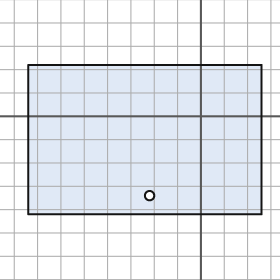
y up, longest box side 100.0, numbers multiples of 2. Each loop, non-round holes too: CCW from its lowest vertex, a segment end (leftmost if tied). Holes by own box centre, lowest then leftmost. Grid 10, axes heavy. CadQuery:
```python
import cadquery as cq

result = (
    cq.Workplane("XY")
    .moveTo(-74.0, -42.0)
    .lineTo(26.0, -42.0)
    .lineTo(26.0, 22.0)
    .lineTo(-74.0, 22.0)
    .close()
    .moveTo(-22.0, -34.0)
    .circle(2.0)
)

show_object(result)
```